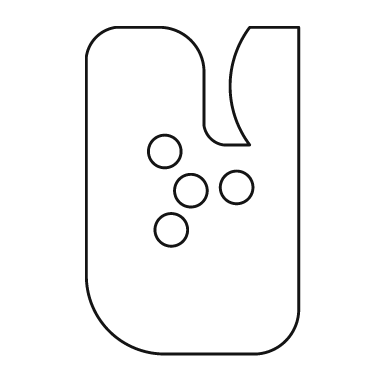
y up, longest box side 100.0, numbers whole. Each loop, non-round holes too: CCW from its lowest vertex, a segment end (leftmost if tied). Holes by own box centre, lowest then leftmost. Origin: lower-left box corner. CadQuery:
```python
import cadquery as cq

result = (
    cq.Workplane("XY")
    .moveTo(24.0, 0.0)
    .lineTo(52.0, 0.0)
    .threePointArc((61.0, 4.0), (65.0, 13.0))
    .lineTo(65.0, 100.0)
    .lineTo(50.0, 100.0)
    .threePointArc((44.0, 82.0), (50.0, 64.0))
    .lineTo(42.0, 64.0)
    .threePointArc((38.0, 66.0), (36.0, 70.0))
    .lineTo(36.0, 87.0)
    .threePointArc((32.0, 96.0), (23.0, 100.0))
    .lineTo(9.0, 100.0)
    .threePointArc((3.0, 97.0), (0.0, 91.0))
    .lineTo(0.0, 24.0)
    .threePointArc((7.0, 7.0), (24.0, 0.0))
    .close()
    .moveTo(26.0, 38.0)
    .circle(5.0)
    .moveTo(32.0, 50.0)
    .circle(5.0)
    .moveTo(46.0, 51.0)
    .circle(5.0)
    .moveTo(24.0, 62.0)
    .circle(5.0)
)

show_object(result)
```